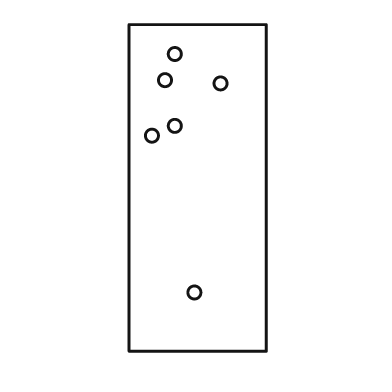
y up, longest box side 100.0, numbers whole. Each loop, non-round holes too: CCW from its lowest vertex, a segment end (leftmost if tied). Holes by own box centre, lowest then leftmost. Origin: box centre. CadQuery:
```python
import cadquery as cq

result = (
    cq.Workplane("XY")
    .moveTo(-21.0, -50.0)
    .lineTo(21.0, -50.0)
    .lineTo(21.0, 50.0)
    .lineTo(-21.0, 50.0)
    .close()
    .moveTo(-1.0, -32.0)
    .circle(2.0)
    .moveTo(-14.0, 16.0)
    .circle(2.0)
    .moveTo(-7.0, 19.0)
    .circle(2.0)
    .moveTo(7.0, 32.0)
    .circle(2.0)
    .moveTo(-10.0, 33.0)
    .circle(2.0)
    .moveTo(-7.0, 41.0)
    .circle(2.0)
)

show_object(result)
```